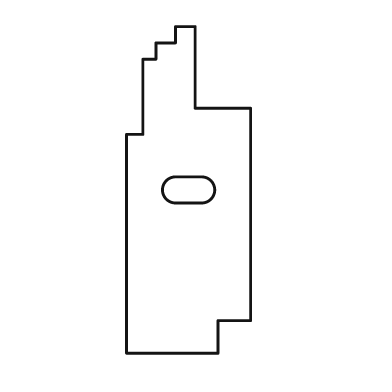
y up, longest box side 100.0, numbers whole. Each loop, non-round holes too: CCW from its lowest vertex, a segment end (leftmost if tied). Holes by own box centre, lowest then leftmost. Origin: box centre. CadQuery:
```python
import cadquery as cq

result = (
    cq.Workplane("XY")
    .moveTo(-19.0, -50.0)
    .lineTo(9.0, -50.0)
    .lineTo(9.0, -40.0)
    .lineTo(19.0, -40.0)
    .lineTo(19.0, 25.0)
    .lineTo(2.0, 25.0)
    .lineTo(2.0, 50.0)
    .lineTo(-4.0, 50.0)
    .lineTo(-4.0, 45.0)
    .lineTo(-10.0, 45.0)
    .lineTo(-10.0, 40.0)
    .lineTo(-14.0, 40.0)
    .lineTo(-14.0, 17.0)
    .lineTo(-19.0, 17.0)
    .close()
    .moveTo(-4.0, -4.0)
    .lineTo(4.0, -4.0)
    .threePointArc((8.0, 0.0), (4.0, 4.0))
    .lineTo(-4.0, 4.0)
    .threePointArc((-8.0, 0.0), (-4.0, -4.0))
    .close()
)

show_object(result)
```